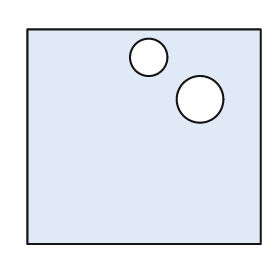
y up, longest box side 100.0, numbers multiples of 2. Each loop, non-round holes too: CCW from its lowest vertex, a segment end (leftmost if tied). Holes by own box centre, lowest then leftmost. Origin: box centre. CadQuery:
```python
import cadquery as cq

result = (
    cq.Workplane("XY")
    .moveTo(-50.0, -46.0)
    .lineTo(50.0, -46.0)
    .lineTo(50.0, 46.0)
    .lineTo(-50.0, 46.0)
    .close()
    .moveTo(24.0, 16.0)
    .circle(10.0)
    .moveTo(2.0, 34.0)
    .circle(8.0)
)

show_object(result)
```